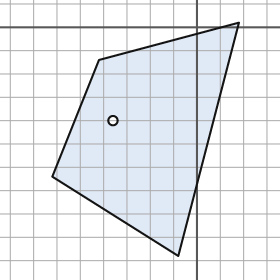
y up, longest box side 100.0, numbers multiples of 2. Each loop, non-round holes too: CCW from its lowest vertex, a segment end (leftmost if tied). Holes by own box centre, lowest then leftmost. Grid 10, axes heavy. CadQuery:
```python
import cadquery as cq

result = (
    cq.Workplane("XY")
    .moveTo(-8.0, -98.0)
    .lineTo(18.0, 2.0)
    .lineTo(-42.0, -14.0)
    .lineTo(-62.0, -64.0)
    .close()
    .moveTo(-36.0, -40.0)
    .circle(2.0)
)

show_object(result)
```